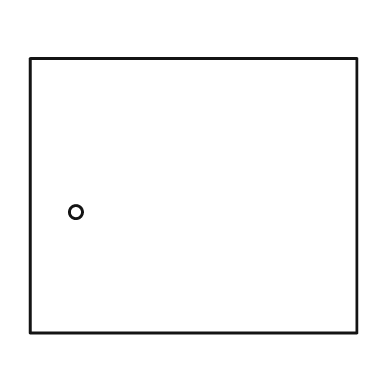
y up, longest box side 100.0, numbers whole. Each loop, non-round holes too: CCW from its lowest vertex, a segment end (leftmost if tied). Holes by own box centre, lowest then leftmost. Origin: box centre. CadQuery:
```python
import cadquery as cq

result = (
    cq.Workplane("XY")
    .moveTo(-50.0, -42.0)
    .lineTo(50.0, -42.0)
    .lineTo(50.0, 42.0)
    .lineTo(-50.0, 42.0)
    .close()
    .moveTo(-36.0, -5.0)
    .circle(2.0)
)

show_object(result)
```